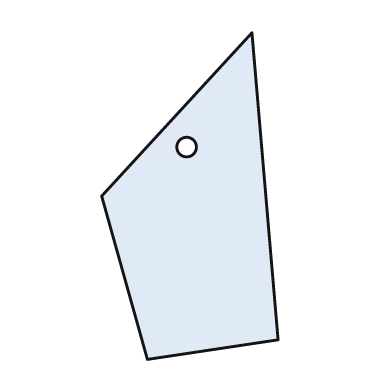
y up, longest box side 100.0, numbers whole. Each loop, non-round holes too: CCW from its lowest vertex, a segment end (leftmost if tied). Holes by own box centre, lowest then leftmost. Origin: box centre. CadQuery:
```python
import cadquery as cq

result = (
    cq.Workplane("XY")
    .moveTo(-13.0, -50.0)
    .lineTo(27.0, -44.0)
    .lineTo(19.0, 50.0)
    .lineTo(-27.0, 0.0)
    .close()
    .moveTo(-1.0, 15.0)
    .circle(3.0)
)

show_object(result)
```